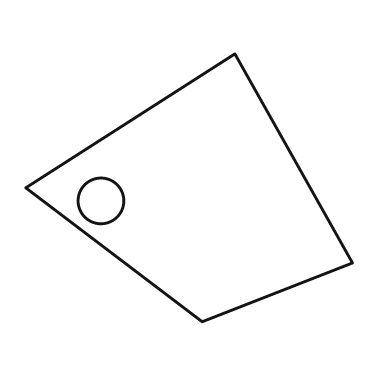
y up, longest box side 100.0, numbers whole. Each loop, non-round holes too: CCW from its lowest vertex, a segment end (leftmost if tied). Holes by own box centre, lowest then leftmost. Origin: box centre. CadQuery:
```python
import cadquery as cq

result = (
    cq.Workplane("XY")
    .moveTo(4.0, -41.0)
    .lineTo(50.0, -23.0)
    .lineTo(14.0, 41.0)
    .lineTo(-50.0, 0.0)
    .close()
    .moveTo(-27.0, -4.0)
    .circle(7.0)
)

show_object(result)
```